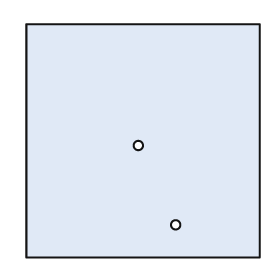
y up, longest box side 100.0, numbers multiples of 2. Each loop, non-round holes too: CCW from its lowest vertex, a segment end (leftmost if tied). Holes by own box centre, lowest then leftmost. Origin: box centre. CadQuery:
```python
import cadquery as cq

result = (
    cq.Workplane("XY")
    .moveTo(-50.0, -50.0)
    .lineTo(50.0, -50.0)
    .lineTo(50.0, 50.0)
    .lineTo(-50.0, 50.0)
    .close()
    .moveTo(14.0, -36.0)
    .circle(2.0)
    .moveTo(-2.0, -2.0)
    .circle(2.0)
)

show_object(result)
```